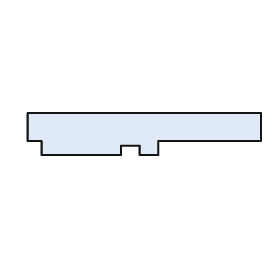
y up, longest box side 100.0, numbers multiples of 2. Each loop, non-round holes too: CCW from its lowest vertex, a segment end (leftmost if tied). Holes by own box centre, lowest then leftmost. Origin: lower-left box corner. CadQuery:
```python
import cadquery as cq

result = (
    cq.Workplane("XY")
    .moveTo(6.0, 0.0)
    .lineTo(40.0, 0.0)
    .lineTo(40.0, 4.0)
    .lineTo(48.0, 4.0)
    .lineTo(48.0, 0.0)
    .lineTo(56.0, 0.0)
    .lineTo(56.0, 6.0)
    .lineTo(100.0, 6.0)
    .lineTo(100.0, 18.0)
    .lineTo(0.0, 18.0)
    .lineTo(0.0, 6.0)
    .lineTo(6.0, 6.0)
    .close()
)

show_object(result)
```